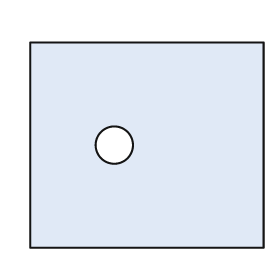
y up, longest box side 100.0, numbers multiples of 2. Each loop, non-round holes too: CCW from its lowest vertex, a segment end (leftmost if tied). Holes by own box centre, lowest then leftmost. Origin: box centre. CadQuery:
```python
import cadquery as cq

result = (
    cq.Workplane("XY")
    .moveTo(-50.0, -44.0)
    .lineTo(50.0, -44.0)
    .lineTo(50.0, 44.0)
    .lineTo(-50.0, 44.0)
    .close()
    .moveTo(-14.0, 0.0)
    .circle(8.0)
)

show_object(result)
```